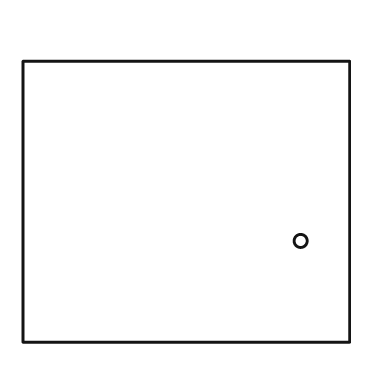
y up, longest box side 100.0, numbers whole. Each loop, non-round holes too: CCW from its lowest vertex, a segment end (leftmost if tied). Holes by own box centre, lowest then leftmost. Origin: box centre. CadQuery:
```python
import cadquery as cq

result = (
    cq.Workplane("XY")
    .moveTo(-50.0, -43.0)
    .lineTo(50.0, -43.0)
    .lineTo(50.0, 43.0)
    .lineTo(-50.0, 43.0)
    .close()
    .moveTo(35.0, -12.0)
    .circle(2.0)
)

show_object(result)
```